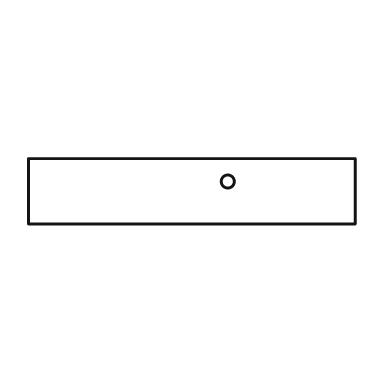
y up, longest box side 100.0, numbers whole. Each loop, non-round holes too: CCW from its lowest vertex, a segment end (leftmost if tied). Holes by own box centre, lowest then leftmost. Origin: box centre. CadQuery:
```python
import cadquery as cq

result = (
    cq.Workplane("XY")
    .moveTo(-50.0, -10.0)
    .lineTo(50.0, -10.0)
    .lineTo(50.0, 10.0)
    .lineTo(-50.0, 10.0)
    .close()
    .moveTo(11.0, 3.0)
    .circle(2.0)
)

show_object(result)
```